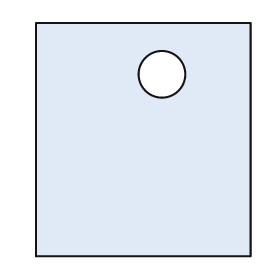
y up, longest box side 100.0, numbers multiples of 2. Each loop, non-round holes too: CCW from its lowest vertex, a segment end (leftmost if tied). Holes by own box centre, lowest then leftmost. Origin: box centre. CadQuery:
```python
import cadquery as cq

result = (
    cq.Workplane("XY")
    .moveTo(-46.0, -50.0)
    .lineTo(46.0, -50.0)
    .lineTo(46.0, 50.0)
    .lineTo(-46.0, 50.0)
    .close()
    .moveTo(8.0, 28.0)
    .circle(10.0)
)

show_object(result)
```